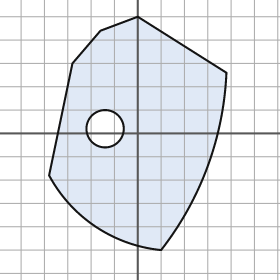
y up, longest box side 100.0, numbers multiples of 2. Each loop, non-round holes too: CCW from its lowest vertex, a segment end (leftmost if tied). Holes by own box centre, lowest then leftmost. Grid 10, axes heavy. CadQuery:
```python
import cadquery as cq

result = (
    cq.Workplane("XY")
    .moveTo(10.0, -50.0)
    .threePointArc((30.0, -14.0), (38.0, 26.0))
    .lineTo(0.0, 50.0)
    .lineTo(-16.0, 44.0)
    .lineTo(-28.0, 30.0)
    .lineTo(-38.0, -18.0)
    .threePointArc((-18.0, -40.0), (10.0, -50.0))
    .close()
    .moveTo(-14.0, 2.0)
    .circle(8.0)
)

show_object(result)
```